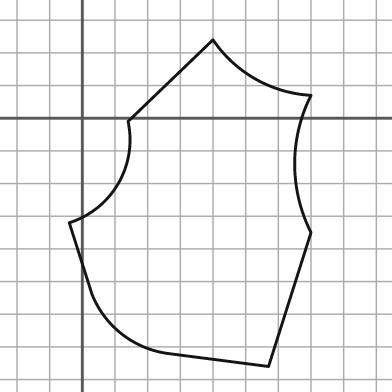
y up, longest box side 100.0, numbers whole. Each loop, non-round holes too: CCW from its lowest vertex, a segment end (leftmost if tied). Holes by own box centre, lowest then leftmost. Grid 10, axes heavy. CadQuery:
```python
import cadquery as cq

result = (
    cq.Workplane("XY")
    .moveTo(57.0, -76.0)
    .lineTo(70.0, -35.0)
    .threePointArc((65.0, -14.0), (70.0, 7.0))
    .threePointArc((53.0, 12.0), (40.0, 24.0))
    .lineTo(14.0, -1.0)
    .threePointArc((11.0, -20.0), (-4.0, -32.0))
    .lineTo(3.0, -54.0)
    .threePointArc((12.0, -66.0), (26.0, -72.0))
    .close()
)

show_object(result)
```